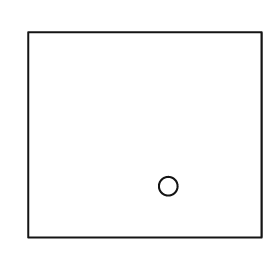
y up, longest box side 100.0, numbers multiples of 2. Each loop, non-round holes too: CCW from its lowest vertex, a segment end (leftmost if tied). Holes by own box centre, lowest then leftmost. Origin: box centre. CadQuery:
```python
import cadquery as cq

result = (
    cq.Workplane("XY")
    .moveTo(-50.0, -44.0)
    .lineTo(50.0, -44.0)
    .lineTo(50.0, 44.0)
    .lineTo(-50.0, 44.0)
    .close()
    .moveTo(10.0, -22.0)
    .circle(4.0)
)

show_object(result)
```